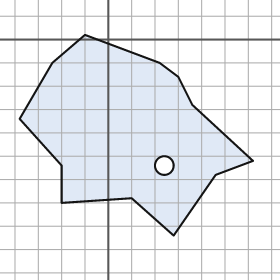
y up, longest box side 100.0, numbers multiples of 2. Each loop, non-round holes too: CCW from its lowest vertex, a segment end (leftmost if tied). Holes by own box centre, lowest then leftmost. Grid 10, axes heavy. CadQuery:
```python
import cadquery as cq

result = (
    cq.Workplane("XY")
    .moveTo(28.0, -84.0)
    .lineTo(46.0, -58.0)
    .lineTo(62.0, -52.0)
    .lineTo(36.0, -28.0)
    .lineTo(30.0, -16.0)
    .lineTo(22.0, -10.0)
    .lineTo(-10.0, 2.0)
    .lineTo(-24.0, -10.0)
    .lineTo(-38.0, -34.0)
    .lineTo(-20.0, -54.0)
    .lineTo(-20.0, -70.0)
    .lineTo(10.0, -68.0)
    .close()
    .moveTo(24.0, -54.0)
    .circle(4.0)
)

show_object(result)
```